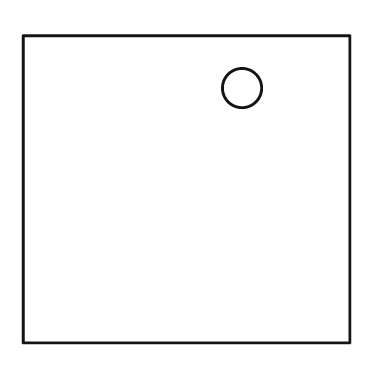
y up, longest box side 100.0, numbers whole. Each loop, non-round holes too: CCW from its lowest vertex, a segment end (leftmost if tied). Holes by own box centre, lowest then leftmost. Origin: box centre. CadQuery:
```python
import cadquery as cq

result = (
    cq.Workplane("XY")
    .moveTo(-50.0, -47.0)
    .lineTo(50.0, -47.0)
    .lineTo(50.0, 47.0)
    .lineTo(-50.0, 47.0)
    .close()
    .moveTo(17.0, 31.0)
    .circle(6.0)
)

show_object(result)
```